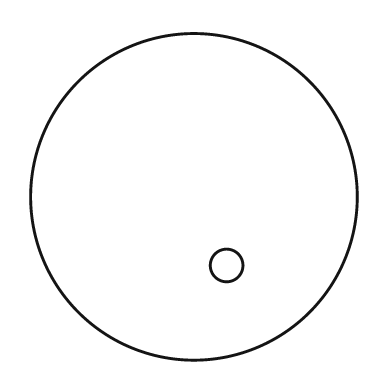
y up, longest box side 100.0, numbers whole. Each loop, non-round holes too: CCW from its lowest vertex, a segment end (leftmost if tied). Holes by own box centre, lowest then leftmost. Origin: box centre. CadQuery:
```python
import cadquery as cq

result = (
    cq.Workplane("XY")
    .moveTo(0.0, 0.0)
    .circle(50.0)
    .moveTo(10.0, -21.0)
    .circle(5.0)
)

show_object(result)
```